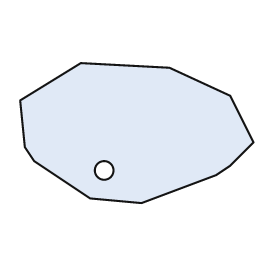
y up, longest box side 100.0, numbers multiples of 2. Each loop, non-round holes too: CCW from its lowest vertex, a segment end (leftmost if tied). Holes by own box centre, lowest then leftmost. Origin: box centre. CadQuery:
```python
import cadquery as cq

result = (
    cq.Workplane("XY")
    .moveTo(2.0, -30.0)
    .lineTo(34.0, -18.0)
    .lineTo(40.0, -14.0)
    .lineTo(50.0, -4.0)
    .lineTo(40.0, 16.0)
    .lineTo(14.0, 28.0)
    .lineTo(-24.0, 30.0)
    .lineTo(-50.0, 14.0)
    .lineTo(-48.0, -6.0)
    .lineTo(-44.0, -12.0)
    .lineTo(-20.0, -28.0)
    .close()
    .moveTo(-14.0, -16.0)
    .circle(4.0)
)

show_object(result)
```